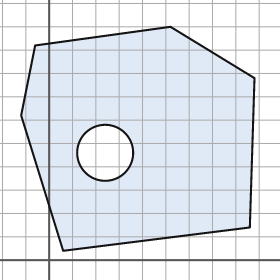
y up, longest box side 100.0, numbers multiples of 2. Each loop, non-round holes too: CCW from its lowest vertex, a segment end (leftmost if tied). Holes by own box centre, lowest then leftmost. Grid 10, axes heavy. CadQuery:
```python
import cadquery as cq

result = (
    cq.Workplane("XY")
    .moveTo(6.0, 4.0)
    .lineTo(86.0, 14.0)
    .lineTo(88.0, 78.0)
    .lineTo(52.0, 100.0)
    .lineTo(-6.0, 92.0)
    .lineTo(-12.0, 62.0)
    .close()
    .moveTo(24.0, 46.0)
    .circle(12.0)
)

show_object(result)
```